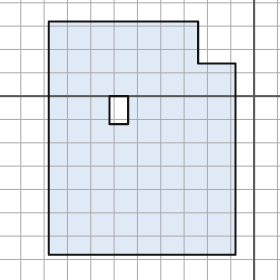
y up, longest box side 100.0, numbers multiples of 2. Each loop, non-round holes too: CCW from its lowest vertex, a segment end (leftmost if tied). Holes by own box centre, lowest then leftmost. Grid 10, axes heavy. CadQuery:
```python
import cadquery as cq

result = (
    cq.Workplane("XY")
    .moveTo(-88.0, -68.0)
    .lineTo(-8.0, -68.0)
    .lineTo(-8.0, 14.0)
    .lineTo(-24.0, 14.0)
    .lineTo(-24.0, 32.0)
    .lineTo(-88.0, 32.0)
    .close()
    .moveTo(-62.0, -12.0)
    .lineTo(-54.0, -12.0)
    .lineTo(-54.0, 0.0)
    .lineTo(-62.0, 0.0)
    .close()
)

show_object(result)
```